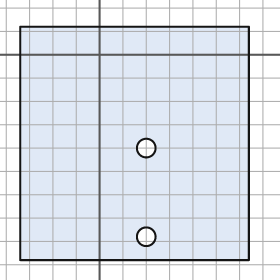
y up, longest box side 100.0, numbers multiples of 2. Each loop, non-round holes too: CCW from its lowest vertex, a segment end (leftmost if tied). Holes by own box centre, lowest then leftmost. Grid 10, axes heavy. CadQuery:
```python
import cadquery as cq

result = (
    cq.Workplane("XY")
    .moveTo(-34.0, -88.0)
    .lineTo(64.0, -88.0)
    .lineTo(64.0, 12.0)
    .lineTo(-34.0, 12.0)
    .close()
    .moveTo(20.0, -78.0)
    .circle(4.0)
    .moveTo(20.0, -40.0)
    .circle(4.0)
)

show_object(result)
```